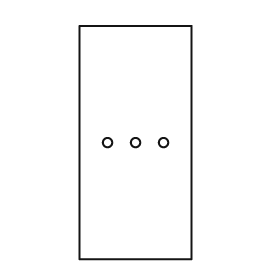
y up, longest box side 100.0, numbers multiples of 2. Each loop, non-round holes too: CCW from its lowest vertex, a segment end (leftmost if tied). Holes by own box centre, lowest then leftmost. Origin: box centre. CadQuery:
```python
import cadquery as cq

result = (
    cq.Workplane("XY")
    .moveTo(-24.0, -50.0)
    .lineTo(24.0, -50.0)
    .lineTo(24.0, 50.0)
    .lineTo(-24.0, 50.0)
    .close()
    .moveTo(-12.0, 0.0)
    .circle(2.0)
    .moveTo(0.0, 0.0)
    .circle(2.0)
    .moveTo(12.0, 0.0)
    .circle(2.0)
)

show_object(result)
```